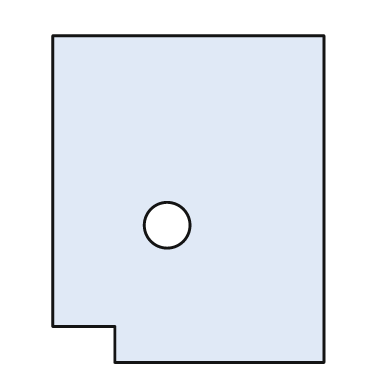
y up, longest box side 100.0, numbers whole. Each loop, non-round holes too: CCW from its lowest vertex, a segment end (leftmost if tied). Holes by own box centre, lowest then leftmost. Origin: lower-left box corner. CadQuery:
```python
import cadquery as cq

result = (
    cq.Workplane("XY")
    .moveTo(19.0, 0.0)
    .lineTo(83.0, 0.0)
    .lineTo(83.0, 100.0)
    .lineTo(0.0, 100.0)
    .lineTo(0.0, 11.0)
    .lineTo(19.0, 11.0)
    .close()
    .moveTo(35.0, 42.0)
    .circle(7.0)
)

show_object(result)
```